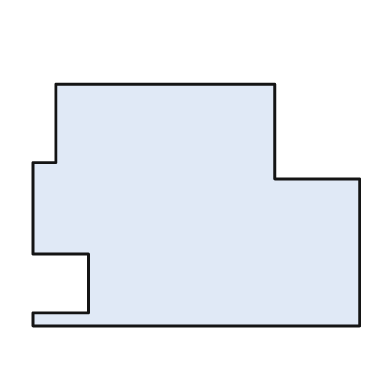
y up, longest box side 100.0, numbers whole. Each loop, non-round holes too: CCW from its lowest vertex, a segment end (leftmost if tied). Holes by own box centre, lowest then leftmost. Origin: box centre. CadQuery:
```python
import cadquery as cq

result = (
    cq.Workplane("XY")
    .moveTo(-50.0, -37.0)
    .lineTo(50.0, -37.0)
    .lineTo(50.0, 8.0)
    .lineTo(24.0, 8.0)
    .lineTo(24.0, 37.0)
    .lineTo(-43.0, 37.0)
    .lineTo(-43.0, 13.0)
    .lineTo(-50.0, 13.0)
    .lineTo(-50.0, -15.0)
    .lineTo(-33.0, -15.0)
    .lineTo(-33.0, -33.0)
    .lineTo(-50.0, -33.0)
    .close()
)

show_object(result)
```